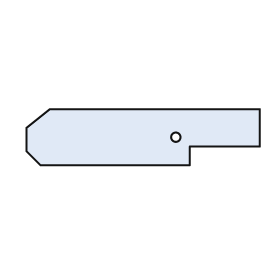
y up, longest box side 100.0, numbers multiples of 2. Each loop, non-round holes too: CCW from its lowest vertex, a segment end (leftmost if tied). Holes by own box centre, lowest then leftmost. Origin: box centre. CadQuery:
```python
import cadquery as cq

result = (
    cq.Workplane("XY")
    .moveTo(-44.0, -12.0)
    .lineTo(20.0, -12.0)
    .lineTo(20.0, -4.0)
    .lineTo(50.0, -4.0)
    .lineTo(50.0, 12.0)
    .lineTo(-40.0, 12.0)
    .lineTo(-50.0, 4.0)
    .lineTo(-50.0, -6.0)
    .close()
    .moveTo(14.0, 0.0)
    .circle(2.0)
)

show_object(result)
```